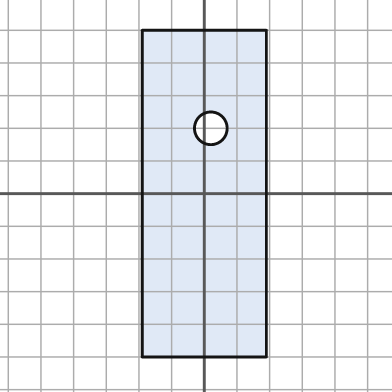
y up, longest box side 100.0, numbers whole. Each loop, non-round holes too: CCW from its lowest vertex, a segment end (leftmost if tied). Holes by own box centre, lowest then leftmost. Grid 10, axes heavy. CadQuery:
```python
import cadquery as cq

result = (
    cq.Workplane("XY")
    .moveTo(-19.0, -50.0)
    .lineTo(19.0, -50.0)
    .lineTo(19.0, 50.0)
    .lineTo(-19.0, 50.0)
    .close()
    .moveTo(2.0, 20.0)
    .circle(5.0)
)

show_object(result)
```